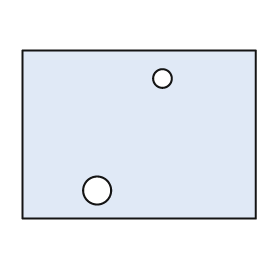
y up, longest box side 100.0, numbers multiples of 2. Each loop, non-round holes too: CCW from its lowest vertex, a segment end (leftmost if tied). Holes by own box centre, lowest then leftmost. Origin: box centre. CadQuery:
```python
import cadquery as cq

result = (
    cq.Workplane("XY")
    .moveTo(-50.0, -36.0)
    .lineTo(50.0, -36.0)
    .lineTo(50.0, 36.0)
    .lineTo(-50.0, 36.0)
    .close()
    .moveTo(-18.0, -24.0)
    .circle(6.0)
    .moveTo(10.0, 24.0)
    .circle(4.0)
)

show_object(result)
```